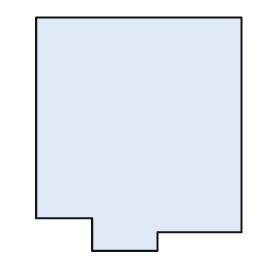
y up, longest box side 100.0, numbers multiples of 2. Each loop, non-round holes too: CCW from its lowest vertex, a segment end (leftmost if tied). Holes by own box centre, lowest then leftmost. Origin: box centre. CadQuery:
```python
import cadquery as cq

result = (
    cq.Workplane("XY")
    .moveTo(-20.0, -50.0)
    .lineTo(8.0, -50.0)
    .lineTo(8.0, -42.0)
    .lineTo(44.0, -42.0)
    .lineTo(44.0, 50.0)
    .lineTo(-44.0, 50.0)
    .lineTo(-44.0, -36.0)
    .lineTo(-20.0, -36.0)
    .close()
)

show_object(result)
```